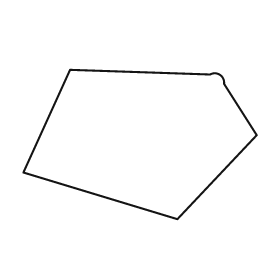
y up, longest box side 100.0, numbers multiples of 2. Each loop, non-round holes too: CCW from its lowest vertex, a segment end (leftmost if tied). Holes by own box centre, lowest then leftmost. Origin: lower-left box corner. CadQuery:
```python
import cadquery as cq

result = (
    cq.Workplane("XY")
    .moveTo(66.0, 0.0)
    .lineTo(100.0, 36.0)
    .lineTo(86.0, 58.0)
    .threePointArc((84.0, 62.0), (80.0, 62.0))
    .lineTo(20.0, 64.0)
    .lineTo(0.0, 20.0)
    .close()
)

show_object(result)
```